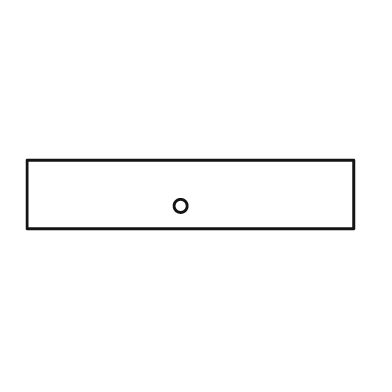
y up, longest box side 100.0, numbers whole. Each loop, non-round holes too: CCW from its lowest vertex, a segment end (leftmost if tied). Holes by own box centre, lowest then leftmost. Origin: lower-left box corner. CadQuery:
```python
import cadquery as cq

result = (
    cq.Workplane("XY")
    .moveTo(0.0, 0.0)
    .lineTo(100.0, 0.0)
    .lineTo(100.0, 21.0)
    .lineTo(0.0, 21.0)
    .close()
    .moveTo(47.0, 7.0)
    .circle(2.0)
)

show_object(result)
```